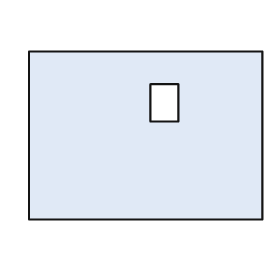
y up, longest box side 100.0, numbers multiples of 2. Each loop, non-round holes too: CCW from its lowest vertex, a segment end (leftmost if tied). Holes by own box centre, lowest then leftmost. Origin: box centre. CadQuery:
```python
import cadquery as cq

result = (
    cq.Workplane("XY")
    .moveTo(-50.0, -36.0)
    .lineTo(50.0, -36.0)
    .lineTo(50.0, 36.0)
    .lineTo(-50.0, 36.0)
    .close()
    .moveTo(2.0, 6.0)
    .lineTo(14.0, 6.0)
    .lineTo(14.0, 22.0)
    .lineTo(2.0, 22.0)
    .close()
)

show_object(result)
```